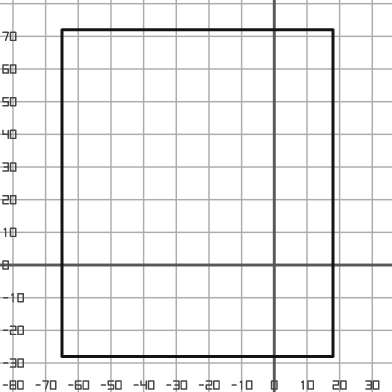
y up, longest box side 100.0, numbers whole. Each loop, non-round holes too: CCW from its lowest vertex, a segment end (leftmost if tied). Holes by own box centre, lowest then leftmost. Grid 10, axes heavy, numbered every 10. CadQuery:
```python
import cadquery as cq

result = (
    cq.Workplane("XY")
    .moveTo(-65.0, -28.0)
    .lineTo(18.0, -28.0)
    .lineTo(18.0, 72.0)
    .lineTo(-65.0, 72.0)
    .close()
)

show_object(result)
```